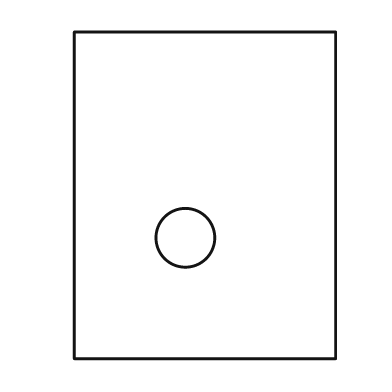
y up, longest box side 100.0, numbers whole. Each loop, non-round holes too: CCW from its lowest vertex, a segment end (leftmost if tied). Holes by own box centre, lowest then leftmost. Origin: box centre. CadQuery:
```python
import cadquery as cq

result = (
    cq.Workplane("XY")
    .moveTo(-40.0, -50.0)
    .lineTo(40.0, -50.0)
    .lineTo(40.0, 50.0)
    .lineTo(-40.0, 50.0)
    .close()
    .moveTo(-6.0, -13.0)
    .circle(9.0)
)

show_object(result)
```